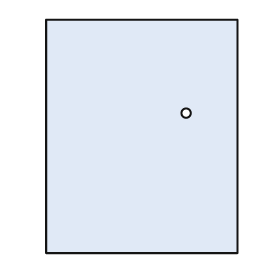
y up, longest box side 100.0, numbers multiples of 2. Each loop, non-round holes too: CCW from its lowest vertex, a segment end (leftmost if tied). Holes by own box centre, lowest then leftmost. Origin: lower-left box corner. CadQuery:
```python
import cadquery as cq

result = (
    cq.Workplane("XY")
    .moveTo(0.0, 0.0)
    .lineTo(82.0, 0.0)
    .lineTo(82.0, 100.0)
    .lineTo(0.0, 100.0)
    .close()
    .moveTo(60.0, 60.0)
    .circle(2.0)
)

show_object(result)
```